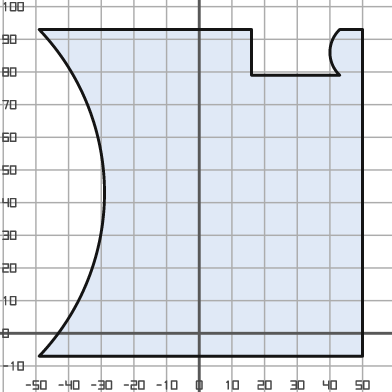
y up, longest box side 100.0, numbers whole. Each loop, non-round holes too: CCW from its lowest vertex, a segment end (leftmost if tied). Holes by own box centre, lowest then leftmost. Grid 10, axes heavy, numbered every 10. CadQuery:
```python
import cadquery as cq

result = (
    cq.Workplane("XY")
    .moveTo(-49.0, -7.0)
    .lineTo(50.0, -7.0)
    .lineTo(50.0, 93.0)
    .lineTo(43.0, 93.0)
    .threePointArc((40.0, 86.0), (43.0, 79.0))
    .lineTo(16.0, 79.0)
    .lineTo(16.0, 93.0)
    .lineTo(-49.0, 93.0)
    .threePointArc((-29.0, 43.0), (-49.0, -7.0))
    .close()
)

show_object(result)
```